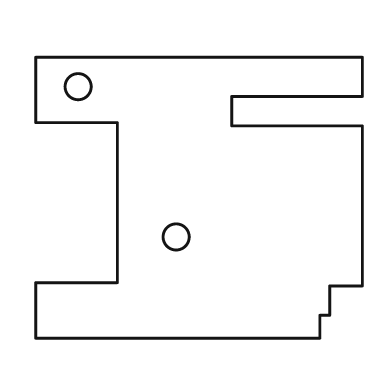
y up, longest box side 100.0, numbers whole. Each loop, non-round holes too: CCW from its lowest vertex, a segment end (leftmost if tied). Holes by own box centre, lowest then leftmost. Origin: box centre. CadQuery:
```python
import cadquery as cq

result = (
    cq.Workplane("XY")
    .moveTo(-50.0, -43.0)
    .lineTo(37.0, -43.0)
    .lineTo(37.0, -36.0)
    .lineTo(40.0, -36.0)
    .lineTo(40.0, -27.0)
    .lineTo(50.0, -27.0)
    .lineTo(50.0, 22.0)
    .lineTo(10.0, 22.0)
    .lineTo(10.0, 31.0)
    .lineTo(50.0, 31.0)
    .lineTo(50.0, 43.0)
    .lineTo(-50.0, 43.0)
    .lineTo(-50.0, 23.0)
    .lineTo(-25.0, 23.0)
    .lineTo(-25.0, -26.0)
    .lineTo(-50.0, -26.0)
    .close()
    .moveTo(-7.0, -12.0)
    .circle(4.0)
    .moveTo(-37.0, 34.0)
    .circle(4.0)
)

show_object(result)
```